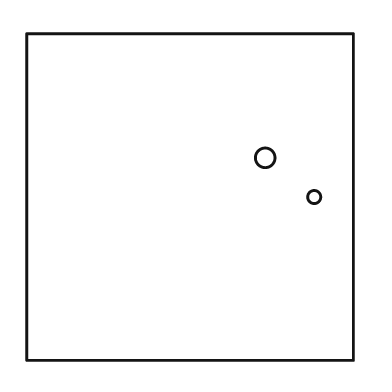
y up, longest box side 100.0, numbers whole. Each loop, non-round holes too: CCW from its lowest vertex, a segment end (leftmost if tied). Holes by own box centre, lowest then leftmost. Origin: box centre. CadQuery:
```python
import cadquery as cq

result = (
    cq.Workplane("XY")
    .moveTo(-50.0, -50.0)
    .lineTo(50.0, -50.0)
    .lineTo(50.0, 50.0)
    .lineTo(-50.0, 50.0)
    .close()
    .moveTo(38.0, 0.0)
    .circle(2.0)
    .moveTo(23.0, 12.0)
    .circle(3.0)
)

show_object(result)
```